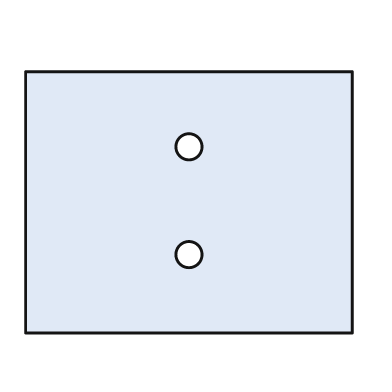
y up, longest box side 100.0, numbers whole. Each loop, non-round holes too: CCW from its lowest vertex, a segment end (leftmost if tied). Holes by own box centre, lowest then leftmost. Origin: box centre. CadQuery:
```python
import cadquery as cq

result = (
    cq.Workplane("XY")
    .moveTo(-50.0, -40.0)
    .lineTo(50.0, -40.0)
    .lineTo(50.0, 40.0)
    .lineTo(-50.0, 40.0)
    .close()
    .moveTo(0.0, -16.0)
    .circle(4.0)
    .moveTo(0.0, 17.0)
    .circle(4.0)
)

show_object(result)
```